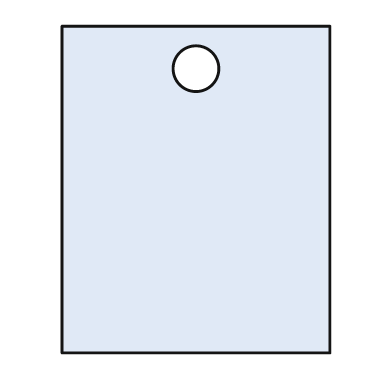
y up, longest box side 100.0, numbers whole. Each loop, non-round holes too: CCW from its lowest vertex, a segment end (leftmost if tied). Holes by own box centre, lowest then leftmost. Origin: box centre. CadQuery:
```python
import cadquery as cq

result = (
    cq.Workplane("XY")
    .moveTo(-41.0, -50.0)
    .lineTo(41.0, -50.0)
    .lineTo(41.0, 50.0)
    .lineTo(-41.0, 50.0)
    .close()
    .moveTo(0.0, 37.0)
    .circle(7.0)
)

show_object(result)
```